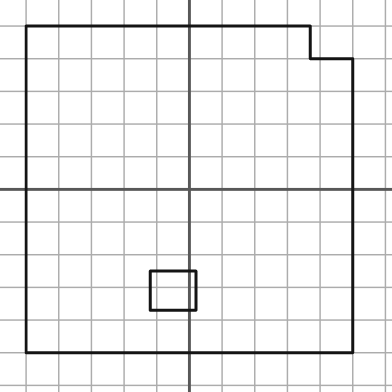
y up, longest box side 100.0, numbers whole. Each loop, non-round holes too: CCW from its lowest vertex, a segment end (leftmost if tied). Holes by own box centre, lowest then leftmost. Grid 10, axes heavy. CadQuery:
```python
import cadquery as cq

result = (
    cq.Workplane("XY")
    .moveTo(-50.0, -50.0)
    .lineTo(50.0, -50.0)
    .lineTo(50.0, 40.0)
    .lineTo(37.0, 40.0)
    .lineTo(37.0, 50.0)
    .lineTo(-50.0, 50.0)
    .close()
    .moveTo(-12.0, -37.0)
    .lineTo(2.0, -37.0)
    .lineTo(2.0, -25.0)
    .lineTo(-12.0, -25.0)
    .close()
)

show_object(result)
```